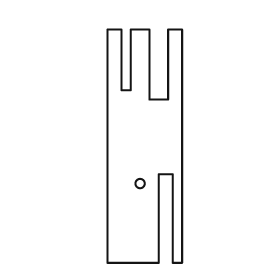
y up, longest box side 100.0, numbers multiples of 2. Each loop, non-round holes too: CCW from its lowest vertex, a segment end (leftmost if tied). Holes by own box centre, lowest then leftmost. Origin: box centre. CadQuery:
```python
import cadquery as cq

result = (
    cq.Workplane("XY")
    .moveTo(-16.0, -50.0)
    .lineTo(6.0, -50.0)
    .lineTo(6.0, -12.0)
    .lineTo(12.0, -12.0)
    .lineTo(12.0, -50.0)
    .lineTo(16.0, -50.0)
    .lineTo(16.0, 50.0)
    .lineTo(10.0, 50.0)
    .lineTo(10.0, 20.0)
    .lineTo(2.0, 20.0)
    .lineTo(2.0, 50.0)
    .lineTo(-6.0, 50.0)
    .lineTo(-6.0, 24.0)
    .lineTo(-10.0, 24.0)
    .lineTo(-10.0, 50.0)
    .lineTo(-16.0, 50.0)
    .close()
    .moveTo(-2.0, -16.0)
    .circle(2.0)
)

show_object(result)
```